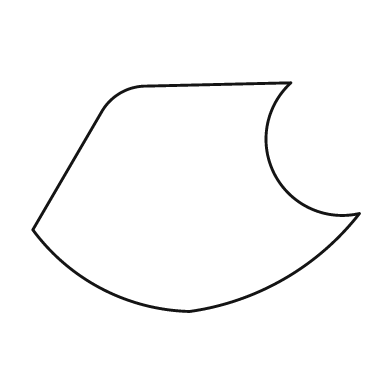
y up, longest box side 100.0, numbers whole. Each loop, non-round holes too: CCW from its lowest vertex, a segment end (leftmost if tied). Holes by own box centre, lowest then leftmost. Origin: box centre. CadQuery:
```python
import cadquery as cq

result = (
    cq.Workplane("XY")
    .moveTo(-2.0, -35.0)
    .threePointArc((27.0, -25.0), (50.0, -5.0))
    .threePointArc((24.0, 7.0), (29.0, 35.0))
    .lineTo(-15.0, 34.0)
    .threePointArc((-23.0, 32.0), (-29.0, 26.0))
    .lineTo(-50.0, -10.0)
    .threePointArc((-29.0, -28.0), (-2.0, -35.0))
    .close()
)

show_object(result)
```